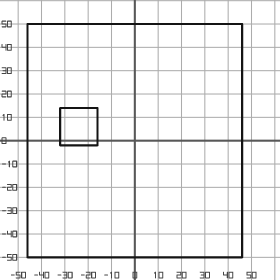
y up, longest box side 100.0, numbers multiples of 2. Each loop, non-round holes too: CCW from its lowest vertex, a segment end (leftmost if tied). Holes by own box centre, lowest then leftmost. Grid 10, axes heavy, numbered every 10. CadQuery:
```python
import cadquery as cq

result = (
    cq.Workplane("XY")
    .moveTo(-46.0, -50.0)
    .lineTo(46.0, -50.0)
    .lineTo(46.0, 50.0)
    .lineTo(-46.0, 50.0)
    .close()
    .moveTo(-32.0, -2.0)
    .lineTo(-16.0, -2.0)
    .lineTo(-16.0, 14.0)
    .lineTo(-32.0, 14.0)
    .close()
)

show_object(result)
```